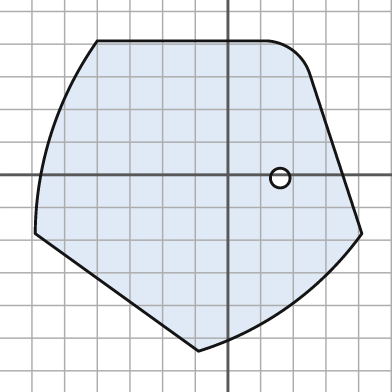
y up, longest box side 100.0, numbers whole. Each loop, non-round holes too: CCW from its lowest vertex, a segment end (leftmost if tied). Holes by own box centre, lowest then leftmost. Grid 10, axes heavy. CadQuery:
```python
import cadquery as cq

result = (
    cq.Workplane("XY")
    .moveTo(-9.0, -54.0)
    .threePointArc((19.0, -40.0), (41.0, -18.0))
    .lineTo(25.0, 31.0)
    .threePointArc((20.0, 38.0), (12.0, 41.0))
    .lineTo(-40.0, 41.0)
    .threePointArc((-54.0, 13.0), (-59.0, -18.0))
    .close()
    .moveTo(16.0, -1.0)
    .circle(3.0)
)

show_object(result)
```